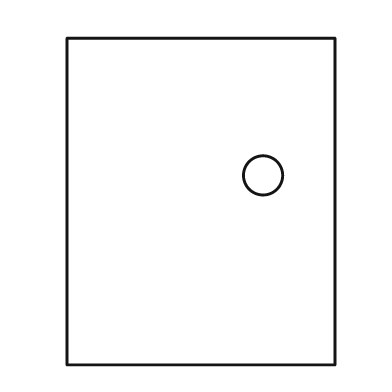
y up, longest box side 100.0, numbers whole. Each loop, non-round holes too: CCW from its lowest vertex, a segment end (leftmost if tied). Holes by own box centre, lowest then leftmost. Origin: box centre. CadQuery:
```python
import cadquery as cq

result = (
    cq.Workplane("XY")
    .moveTo(-41.0, -50.0)
    .lineTo(41.0, -50.0)
    .lineTo(41.0, 50.0)
    .lineTo(-41.0, 50.0)
    .close()
    .moveTo(19.0, 8.0)
    .circle(6.0)
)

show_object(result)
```